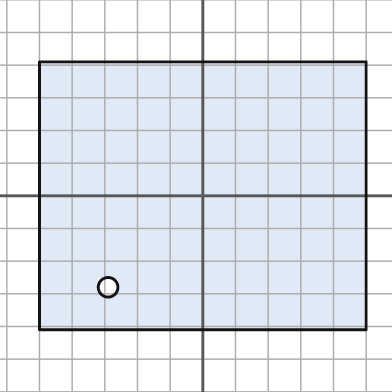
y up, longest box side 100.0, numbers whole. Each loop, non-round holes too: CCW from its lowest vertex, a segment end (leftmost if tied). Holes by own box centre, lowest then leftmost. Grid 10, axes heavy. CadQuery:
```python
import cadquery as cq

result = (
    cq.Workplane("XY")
    .moveTo(-50.0, -41.0)
    .lineTo(50.0, -41.0)
    .lineTo(50.0, 41.0)
    .lineTo(-50.0, 41.0)
    .close()
    .moveTo(-29.0, -28.0)
    .circle(3.0)
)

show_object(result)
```